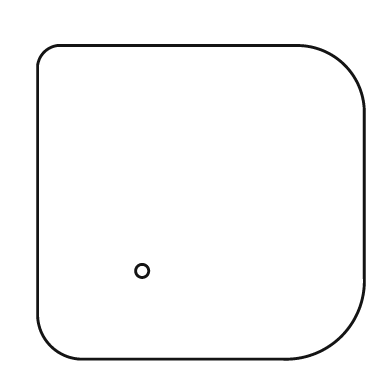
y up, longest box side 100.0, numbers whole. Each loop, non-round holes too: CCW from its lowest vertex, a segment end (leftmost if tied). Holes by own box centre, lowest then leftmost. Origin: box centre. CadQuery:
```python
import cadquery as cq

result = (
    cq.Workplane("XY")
    .moveTo(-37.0, -48.0)
    .lineTo(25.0, -48.0)
    .threePointArc((43.0, -41.0), (50.0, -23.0))
    .lineTo(50.0, 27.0)
    .threePointArc((44.0, 42.0), (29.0, 48.0))
    .lineTo(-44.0, 48.0)
    .threePointArc((-48.0, 46.0), (-50.0, 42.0))
    .lineTo(-50.0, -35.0)
    .threePointArc((-46.0, -44.0), (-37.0, -48.0))
    .close()
    .moveTo(-18.0, -21.0)
    .circle(2.0)
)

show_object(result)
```